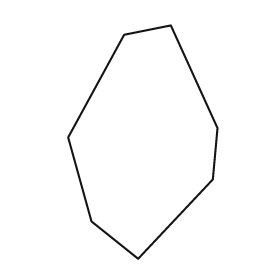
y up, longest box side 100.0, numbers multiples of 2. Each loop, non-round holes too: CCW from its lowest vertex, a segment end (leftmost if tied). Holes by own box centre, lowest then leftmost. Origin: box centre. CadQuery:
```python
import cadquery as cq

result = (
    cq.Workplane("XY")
    .moveTo(-2.0, -50.0)
    .lineTo(30.0, -16.0)
    .lineTo(32.0, 6.0)
    .lineTo(12.0, 50.0)
    .lineTo(-8.0, 46.0)
    .lineTo(-32.0, 2.0)
    .lineTo(-22.0, -34.0)
    .close()
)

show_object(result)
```